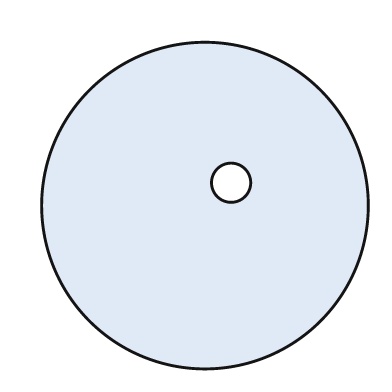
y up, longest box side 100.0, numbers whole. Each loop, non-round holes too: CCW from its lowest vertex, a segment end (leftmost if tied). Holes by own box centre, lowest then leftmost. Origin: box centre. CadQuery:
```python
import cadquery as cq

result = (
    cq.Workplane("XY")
    .moveTo(0.0, 0.0)
    .circle(50.0)
    .moveTo(8.0, 7.0)
    .circle(6.0)
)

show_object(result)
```